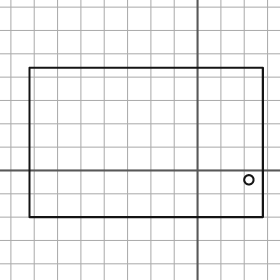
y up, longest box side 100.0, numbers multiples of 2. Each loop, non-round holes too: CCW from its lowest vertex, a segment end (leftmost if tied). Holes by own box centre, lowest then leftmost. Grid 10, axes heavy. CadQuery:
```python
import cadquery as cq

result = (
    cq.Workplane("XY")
    .moveTo(-72.0, -20.0)
    .lineTo(28.0, -20.0)
    .lineTo(28.0, 44.0)
    .lineTo(-72.0, 44.0)
    .close()
    .moveTo(22.0, -4.0)
    .circle(2.0)
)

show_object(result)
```